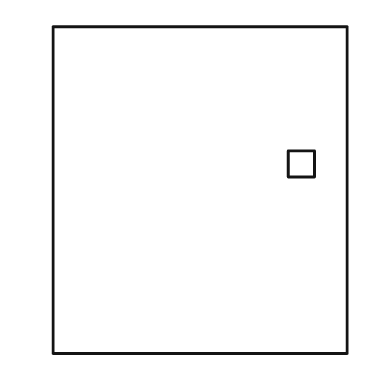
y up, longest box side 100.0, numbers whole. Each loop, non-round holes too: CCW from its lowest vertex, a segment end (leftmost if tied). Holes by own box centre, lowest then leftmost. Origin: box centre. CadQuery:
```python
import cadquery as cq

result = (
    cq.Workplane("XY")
    .moveTo(-45.0, -50.0)
    .lineTo(45.0, -50.0)
    .lineTo(45.0, 50.0)
    .lineTo(-45.0, 50.0)
    .close()
    .moveTo(27.0, 4.0)
    .lineTo(35.0, 4.0)
    .lineTo(35.0, 12.0)
    .lineTo(27.0, 12.0)
    .close()
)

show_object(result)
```